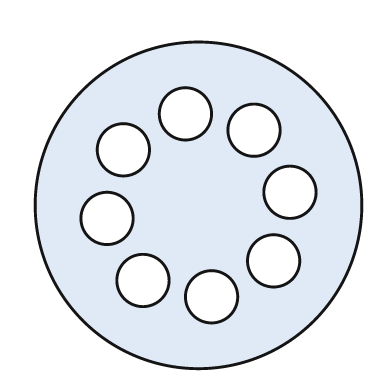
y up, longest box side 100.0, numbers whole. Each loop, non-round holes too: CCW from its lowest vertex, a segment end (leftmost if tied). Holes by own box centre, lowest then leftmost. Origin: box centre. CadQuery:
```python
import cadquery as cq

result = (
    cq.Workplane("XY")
    .moveTo(0.0, 0.0)
    .circle(50.0)
    .moveTo(4.0, -28.0)
    .circle(8.0)
    .moveTo(-17.0, -23.0)
    .circle(8.0)
    .moveTo(23.0, -17.0)
    .circle(8.0)
    .moveTo(-28.0, -4.0)
    .circle(8.0)
    .moveTo(28.0, 4.0)
    .circle(8.0)
    .moveTo(-23.0, 17.0)
    .circle(8.0)
    .moveTo(17.0, 23.0)
    .circle(8.0)
    .moveTo(-4.0, 28.0)
    .circle(8.0)
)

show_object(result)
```